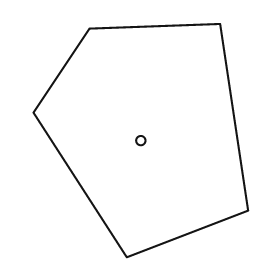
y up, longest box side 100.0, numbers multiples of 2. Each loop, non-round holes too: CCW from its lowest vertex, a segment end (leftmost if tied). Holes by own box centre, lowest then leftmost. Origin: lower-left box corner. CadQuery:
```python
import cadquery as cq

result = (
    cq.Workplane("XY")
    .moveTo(40.0, 0.0)
    .lineTo(92.0, 20.0)
    .lineTo(80.0, 100.0)
    .lineTo(24.0, 98.0)
    .lineTo(0.0, 62.0)
    .close()
    .moveTo(46.0, 50.0)
    .circle(2.0)
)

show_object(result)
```